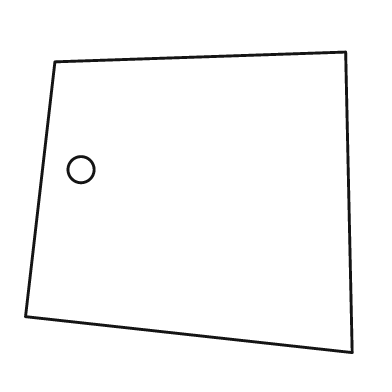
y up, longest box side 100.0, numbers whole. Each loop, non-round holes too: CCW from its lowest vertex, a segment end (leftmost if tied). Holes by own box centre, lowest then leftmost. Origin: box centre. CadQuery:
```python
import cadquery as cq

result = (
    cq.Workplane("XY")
    .moveTo(50.0, -46.0)
    .lineTo(48.0, 46.0)
    .lineTo(-41.0, 43.0)
    .lineTo(-50.0, -35.0)
    .close()
    .moveTo(-33.0, 10.0)
    .circle(4.0)
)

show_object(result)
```